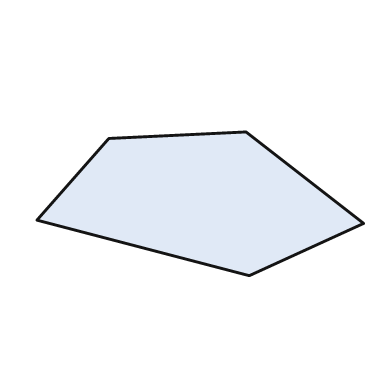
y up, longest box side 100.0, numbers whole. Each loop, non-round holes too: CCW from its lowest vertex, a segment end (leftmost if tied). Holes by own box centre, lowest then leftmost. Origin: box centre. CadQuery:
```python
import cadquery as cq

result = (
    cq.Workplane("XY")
    .moveTo(15.0, -22.0)
    .lineTo(50.0, -6.0)
    .lineTo(14.0, 22.0)
    .lineTo(-28.0, 20.0)
    .lineTo(-50.0, -5.0)
    .close()
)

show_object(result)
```